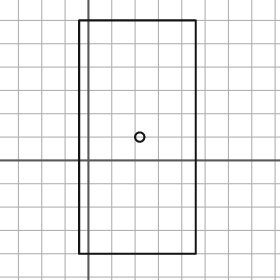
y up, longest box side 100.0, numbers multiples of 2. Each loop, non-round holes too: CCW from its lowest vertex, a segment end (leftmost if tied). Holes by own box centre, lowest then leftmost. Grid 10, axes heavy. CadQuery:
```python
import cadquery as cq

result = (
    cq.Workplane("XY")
    .moveTo(-4.0, -40.0)
    .lineTo(46.0, -40.0)
    .lineTo(46.0, 60.0)
    .lineTo(-4.0, 60.0)
    .close()
    .moveTo(22.0, 10.0)
    .circle(2.0)
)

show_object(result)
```